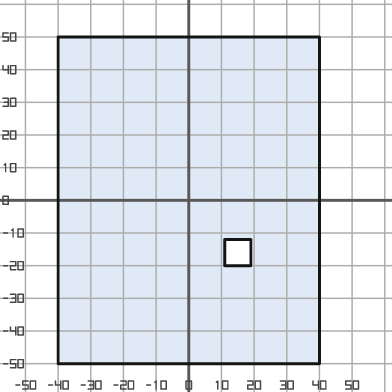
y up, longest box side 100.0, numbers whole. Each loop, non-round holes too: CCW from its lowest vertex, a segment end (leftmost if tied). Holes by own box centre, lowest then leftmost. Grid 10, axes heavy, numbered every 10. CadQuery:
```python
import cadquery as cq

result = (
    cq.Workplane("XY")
    .moveTo(-40.0, -50.0)
    .lineTo(40.0, -50.0)
    .lineTo(40.0, 50.0)
    .lineTo(-40.0, 50.0)
    .close()
    .moveTo(11.0, -20.0)
    .lineTo(19.0, -20.0)
    .lineTo(19.0, -12.0)
    .lineTo(11.0, -12.0)
    .close()
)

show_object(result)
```